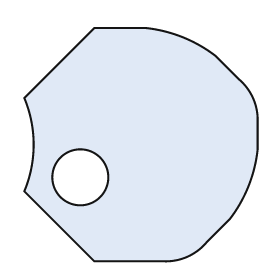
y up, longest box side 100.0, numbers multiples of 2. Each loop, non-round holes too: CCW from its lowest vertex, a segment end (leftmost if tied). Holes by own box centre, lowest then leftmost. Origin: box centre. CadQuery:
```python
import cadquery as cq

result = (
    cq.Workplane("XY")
    .moveTo(-20.0, -50.0)
    .lineTo(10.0, -50.0)
    .threePointArc((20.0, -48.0), (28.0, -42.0))
    .lineTo(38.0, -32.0)
    .threePointArc((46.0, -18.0), (50.0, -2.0))
    .lineTo(50.0, 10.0)
    .threePointArc((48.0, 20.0), (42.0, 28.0))
    .lineTo(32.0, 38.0)
    .threePointArc((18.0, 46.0), (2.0, 50.0))
    .lineTo(-20.0, 50.0)
    .lineTo(-50.0, 20.0)
    .threePointArc((-46.0, 0.0), (-50.0, -20.0))
    .close()
    .moveTo(-26.0, -14.0)
    .circle(12.0)
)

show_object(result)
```